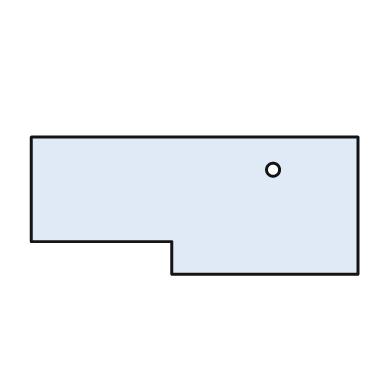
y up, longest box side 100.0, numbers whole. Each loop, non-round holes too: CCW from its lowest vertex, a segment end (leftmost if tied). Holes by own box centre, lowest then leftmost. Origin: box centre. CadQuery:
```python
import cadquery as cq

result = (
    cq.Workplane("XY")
    .moveTo(-7.0, -21.0)
    .lineTo(50.0, -21.0)
    .lineTo(50.0, 21.0)
    .lineTo(-50.0, 21.0)
    .lineTo(-50.0, -11.0)
    .lineTo(-7.0, -11.0)
    .close()
    .moveTo(24.0, 11.0)
    .circle(2.0)
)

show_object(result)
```